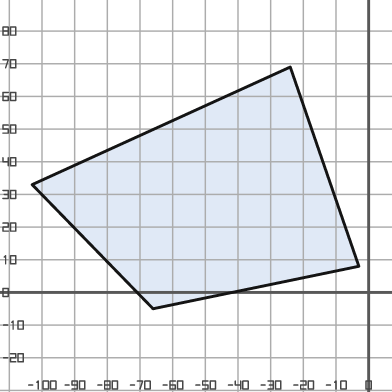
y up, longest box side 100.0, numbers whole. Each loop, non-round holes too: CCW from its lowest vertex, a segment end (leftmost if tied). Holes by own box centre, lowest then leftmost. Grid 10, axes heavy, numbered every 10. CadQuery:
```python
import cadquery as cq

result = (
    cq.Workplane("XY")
    .moveTo(-66.0, -5.0)
    .lineTo(-3.0, 8.0)
    .lineTo(-24.0, 69.0)
    .lineTo(-103.0, 33.0)
    .close()
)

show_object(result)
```